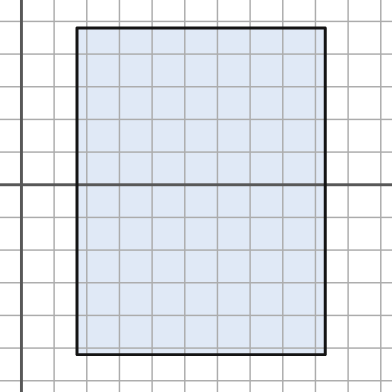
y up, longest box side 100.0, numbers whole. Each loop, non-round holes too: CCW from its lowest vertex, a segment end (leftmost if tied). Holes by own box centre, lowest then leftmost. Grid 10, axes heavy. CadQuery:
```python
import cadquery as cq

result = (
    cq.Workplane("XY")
    .moveTo(17.0, -52.0)
    .lineTo(93.0, -52.0)
    .lineTo(93.0, 48.0)
    .lineTo(17.0, 48.0)
    .close()
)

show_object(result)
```